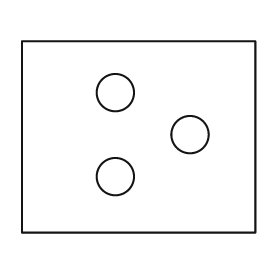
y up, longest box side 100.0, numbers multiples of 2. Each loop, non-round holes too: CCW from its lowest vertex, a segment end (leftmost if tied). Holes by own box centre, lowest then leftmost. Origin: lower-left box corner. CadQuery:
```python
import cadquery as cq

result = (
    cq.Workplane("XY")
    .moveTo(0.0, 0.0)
    .lineTo(100.0, 0.0)
    .lineTo(100.0, 82.0)
    .lineTo(0.0, 82.0)
    .close()
    .moveTo(40.0, 24.0)
    .circle(8.0)
    .moveTo(72.0, 42.0)
    .circle(8.0)
    .moveTo(40.0, 60.0)
    .circle(8.0)
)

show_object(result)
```